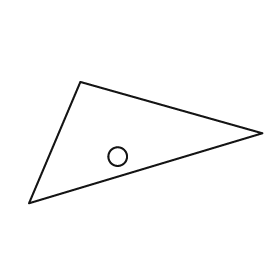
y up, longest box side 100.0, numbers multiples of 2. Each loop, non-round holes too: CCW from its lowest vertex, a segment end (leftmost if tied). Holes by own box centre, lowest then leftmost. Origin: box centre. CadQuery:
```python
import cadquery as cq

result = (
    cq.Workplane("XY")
    .moveTo(-50.0, -26.0)
    .lineTo(50.0, 4.0)
    .lineTo(-28.0, 26.0)
    .close()
    .moveTo(-12.0, -6.0)
    .circle(4.0)
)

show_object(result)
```